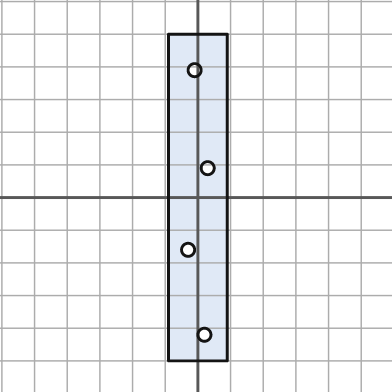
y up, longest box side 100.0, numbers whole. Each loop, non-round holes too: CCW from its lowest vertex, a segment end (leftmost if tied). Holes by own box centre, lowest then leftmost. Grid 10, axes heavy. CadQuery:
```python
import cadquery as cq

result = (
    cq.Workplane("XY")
    .moveTo(-9.0, -50.0)
    .lineTo(9.0, -50.0)
    .lineTo(9.0, 50.0)
    .lineTo(-9.0, 50.0)
    .close()
    .moveTo(2.0, -42.0)
    .circle(2.0)
    .moveTo(-3.0, -16.0)
    .circle(2.0)
    .moveTo(3.0, 9.0)
    .circle(2.0)
    .moveTo(-1.0, 39.0)
    .circle(2.0)
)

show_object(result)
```